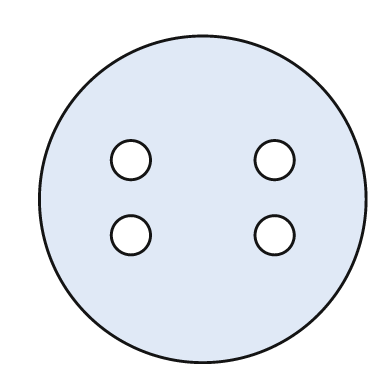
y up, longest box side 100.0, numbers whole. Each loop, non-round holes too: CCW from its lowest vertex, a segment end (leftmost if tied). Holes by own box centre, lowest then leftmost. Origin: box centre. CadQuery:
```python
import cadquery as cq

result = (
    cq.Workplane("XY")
    .moveTo(0.0, 0.0)
    .circle(50.0)
    .moveTo(-22.0, -11.0)
    .circle(6.0)
    .moveTo(22.0, -11.0)
    .circle(6.0)
    .moveTo(-22.0, 12.0)
    .circle(6.0)
    .moveTo(22.0, 12.0)
    .circle(6.0)
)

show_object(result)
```